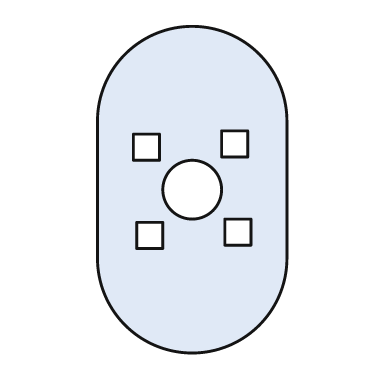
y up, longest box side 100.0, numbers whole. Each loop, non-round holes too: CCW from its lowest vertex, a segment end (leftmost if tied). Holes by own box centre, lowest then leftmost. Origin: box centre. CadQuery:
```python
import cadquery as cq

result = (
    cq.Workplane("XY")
    .moveTo(-29.0, -21.0)
    .threePointArc((0.0, -50.0), (29.0, -21.0))
    .lineTo(29.0, 21.0)
    .threePointArc((0.0, 50.0), (-29.0, 21.0))
    .close()
    .moveTo(-17.0, -18.0)
    .lineTo(-9.0, -18.0)
    .lineTo(-9.0, -10.0)
    .lineTo(-17.0, -10.0)
    .close()
    .moveTo(10.0, -17.0)
    .lineTo(18.0, -17.0)
    .lineTo(18.0, -9.0)
    .lineTo(10.0, -9.0)
    .close()
    .moveTo(0.0, 0.0)
    .circle(9.0)
    .moveTo(-18.0, 9.0)
    .lineTo(-10.0, 9.0)
    .lineTo(-10.0, 17.0)
    .lineTo(-18.0, 17.0)
    .close()
    .moveTo(9.0, 10.0)
    .lineTo(17.0, 10.0)
    .lineTo(17.0, 18.0)
    .lineTo(9.0, 18.0)
    .close()
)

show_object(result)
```